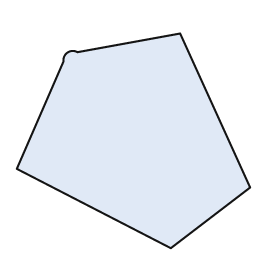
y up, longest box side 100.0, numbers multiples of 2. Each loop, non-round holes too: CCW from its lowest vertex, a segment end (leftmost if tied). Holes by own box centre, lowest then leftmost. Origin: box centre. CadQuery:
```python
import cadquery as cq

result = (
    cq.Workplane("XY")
    .moveTo(16.0, -46.0)
    .lineTo(50.0, -20.0)
    .lineTo(20.0, 46.0)
    .lineTo(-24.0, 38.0)
    .threePointArc((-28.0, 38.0), (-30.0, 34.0))
    .lineTo(-50.0, -12.0)
    .close()
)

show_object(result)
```